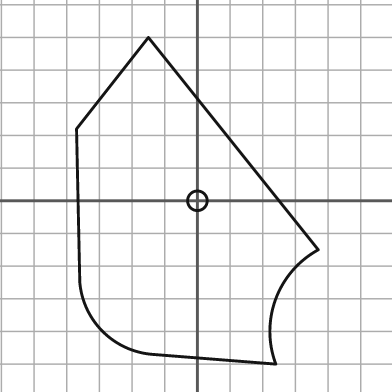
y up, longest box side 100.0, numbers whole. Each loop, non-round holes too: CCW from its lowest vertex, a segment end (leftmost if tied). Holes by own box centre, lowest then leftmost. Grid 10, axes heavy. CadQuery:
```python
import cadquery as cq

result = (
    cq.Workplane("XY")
    .moveTo(24.0, -50.0)
    .threePointArc((24.0, -30.0), (37.0, -15.0))
    .lineTo(-15.0, 50.0)
    .lineTo(-37.0, 22.0)
    .lineTo(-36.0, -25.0)
    .threePointArc((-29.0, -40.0), (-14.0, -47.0))
    .close()
    .moveTo(0.0, 0.0)
    .circle(3.0)
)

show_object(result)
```